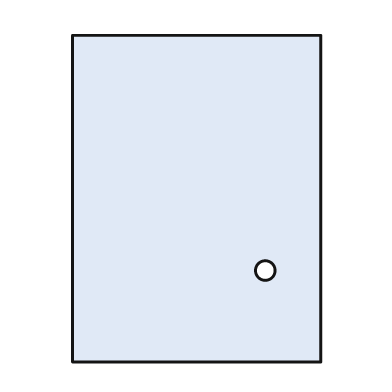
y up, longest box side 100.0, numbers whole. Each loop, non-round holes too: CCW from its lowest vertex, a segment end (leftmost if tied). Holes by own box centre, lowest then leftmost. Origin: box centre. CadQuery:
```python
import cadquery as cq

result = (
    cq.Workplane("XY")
    .moveTo(-38.0, -50.0)
    .lineTo(38.0, -50.0)
    .lineTo(38.0, 50.0)
    .lineTo(-38.0, 50.0)
    .close()
    .moveTo(21.0, -22.0)
    .circle(3.0)
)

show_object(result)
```